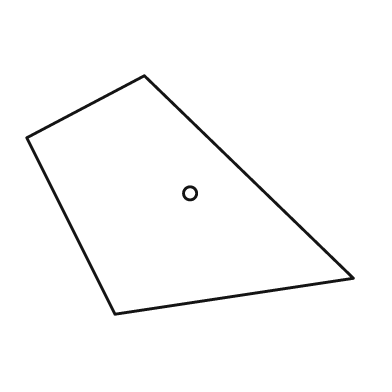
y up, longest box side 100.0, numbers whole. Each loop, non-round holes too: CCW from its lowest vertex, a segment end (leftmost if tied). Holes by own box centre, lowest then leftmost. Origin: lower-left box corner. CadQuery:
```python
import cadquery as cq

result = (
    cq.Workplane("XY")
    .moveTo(27.0, 0.0)
    .lineTo(100.0, 11.0)
    .lineTo(36.0, 73.0)
    .lineTo(0.0, 54.0)
    .close()
    .moveTo(50.0, 37.0)
    .circle(2.0)
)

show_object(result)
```